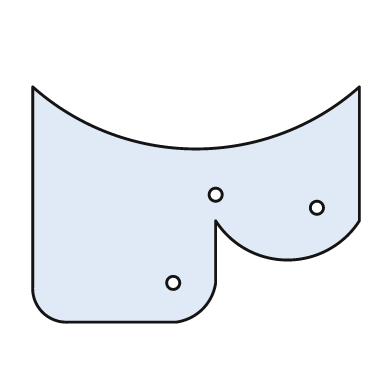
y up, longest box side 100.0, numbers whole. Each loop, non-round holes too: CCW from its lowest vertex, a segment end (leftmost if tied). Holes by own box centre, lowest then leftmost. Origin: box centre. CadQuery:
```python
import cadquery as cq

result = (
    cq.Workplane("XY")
    .moveTo(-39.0, -36.0)
    .lineTo(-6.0, -36.0)
    .threePointArc((2.0, -32.0), (6.0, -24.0))
    .lineTo(6.0, -5.0)
    .threePointArc((28.0, -17.0), (50.0, -5.0))
    .lineTo(50.0, 36.0)
    .threePointArc((0.0, 17.0), (-50.0, 36.0))
    .lineTo(-50.0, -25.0)
    .threePointArc((-47.0, -33.0), (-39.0, -36.0))
    .close()
    .moveTo(-7.0, -24.0)
    .circle(2.0)
    .moveTo(37.0, -1.0)
    .circle(2.0)
    .moveTo(6.0, 3.0)
    .circle(2.0)
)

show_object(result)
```